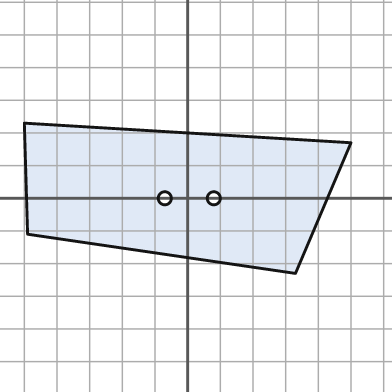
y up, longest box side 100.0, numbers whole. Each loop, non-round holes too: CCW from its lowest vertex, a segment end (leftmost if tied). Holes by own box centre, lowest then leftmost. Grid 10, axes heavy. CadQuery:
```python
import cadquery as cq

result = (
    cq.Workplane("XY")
    .moveTo(33.0, -23.0)
    .lineTo(50.0, 17.0)
    .lineTo(-50.0, 23.0)
    .lineTo(-49.0, -11.0)
    .close()
    .moveTo(-7.0, 0.0)
    .circle(2.0)
    .moveTo(8.0, 0.0)
    .circle(2.0)
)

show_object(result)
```